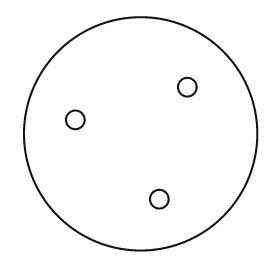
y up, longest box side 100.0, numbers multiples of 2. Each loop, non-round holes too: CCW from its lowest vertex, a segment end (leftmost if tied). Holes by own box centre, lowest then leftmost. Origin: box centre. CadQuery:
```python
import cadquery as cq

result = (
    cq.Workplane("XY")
    .moveTo(0.0, 0.0)
    .circle(50.0)
    .moveTo(8.0, -28.0)
    .circle(4.0)
    .moveTo(-28.0, 6.0)
    .circle(4.0)
    .moveTo(20.0, 20.0)
    .circle(4.0)
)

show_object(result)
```